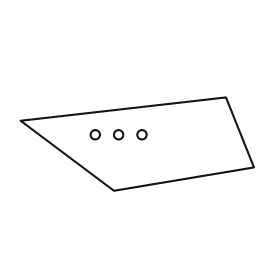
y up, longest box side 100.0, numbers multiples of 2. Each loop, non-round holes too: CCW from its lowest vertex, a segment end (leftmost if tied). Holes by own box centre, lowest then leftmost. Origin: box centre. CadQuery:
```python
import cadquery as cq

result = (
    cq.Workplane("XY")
    .moveTo(-10.0, -20.0)
    .lineTo(50.0, -10.0)
    .lineTo(38.0, 20.0)
    .lineTo(-50.0, 10.0)
    .close()
    .moveTo(-18.0, 4.0)
    .circle(2.0)
    .moveTo(-8.0, 4.0)
    .circle(2.0)
    .moveTo(2.0, 4.0)
    .circle(2.0)
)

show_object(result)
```